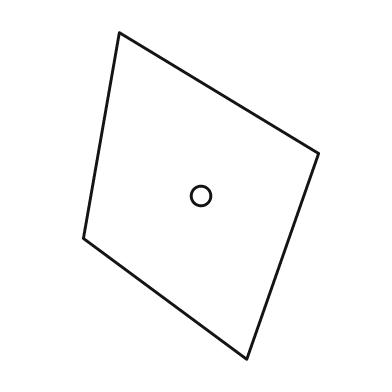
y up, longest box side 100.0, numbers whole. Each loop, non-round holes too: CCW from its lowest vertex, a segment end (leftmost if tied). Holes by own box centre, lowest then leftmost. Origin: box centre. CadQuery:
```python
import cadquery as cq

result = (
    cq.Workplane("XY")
    .moveTo(14.0, -50.0)
    .lineTo(36.0, 13.0)
    .lineTo(-25.0, 50.0)
    .lineTo(-36.0, -13.0)
    .close()
    .moveTo(0.0, 0.0)
    .circle(3.0)
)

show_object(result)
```